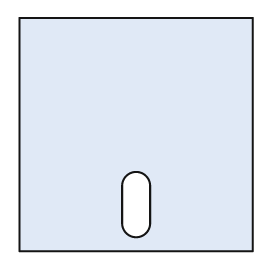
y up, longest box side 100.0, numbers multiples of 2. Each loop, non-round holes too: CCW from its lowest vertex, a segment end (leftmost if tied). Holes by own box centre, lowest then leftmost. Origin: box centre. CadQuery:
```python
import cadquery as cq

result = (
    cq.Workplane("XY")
    .moveTo(-50.0, -50.0)
    .lineTo(50.0, -50.0)
    .lineTo(50.0, 50.0)
    .lineTo(-50.0, 50.0)
    .close()
    .moveTo(-6.0, -38.0)
    .threePointArc((0.0, -44.0), (6.0, -38.0))
    .lineTo(6.0, -22.0)
    .threePointArc((0.0, -16.0), (-6.0, -22.0))
    .close()
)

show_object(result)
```